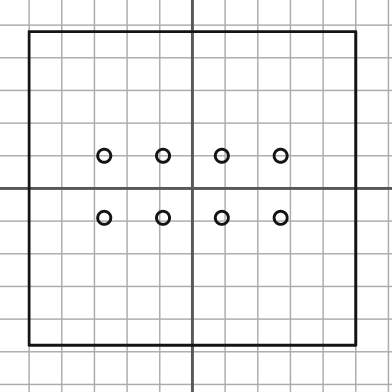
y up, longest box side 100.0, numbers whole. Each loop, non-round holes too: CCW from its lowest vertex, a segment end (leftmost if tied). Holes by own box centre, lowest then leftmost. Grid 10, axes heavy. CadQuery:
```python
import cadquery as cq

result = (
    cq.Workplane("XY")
    .moveTo(-50.0, -48.0)
    .lineTo(50.0, -48.0)
    .lineTo(50.0, 48.0)
    .lineTo(-50.0, 48.0)
    .close()
    .moveTo(-27.0, -9.0)
    .circle(2.0)
    .moveTo(-9.0, -9.0)
    .circle(2.0)
    .moveTo(9.0, -9.0)
    .circle(2.0)
    .moveTo(27.0, -9.0)
    .circle(2.0)
    .moveTo(-27.0, 10.0)
    .circle(2.0)
    .moveTo(-9.0, 10.0)
    .circle(2.0)
    .moveTo(9.0, 10.0)
    .circle(2.0)
    .moveTo(27.0, 10.0)
    .circle(2.0)
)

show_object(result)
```